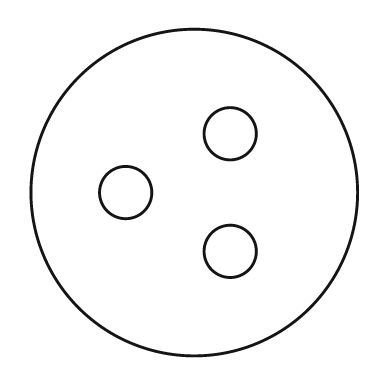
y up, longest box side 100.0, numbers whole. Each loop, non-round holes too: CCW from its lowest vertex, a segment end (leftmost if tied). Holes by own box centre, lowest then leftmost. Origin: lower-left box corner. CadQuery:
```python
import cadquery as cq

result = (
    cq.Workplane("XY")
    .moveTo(50.0, 50.0)
    .circle(50.0)
    .moveTo(61.0, 32.0)
    .circle(8.0)
    .moveTo(29.0, 50.0)
    .circle(8.0)
    .moveTo(61.0, 68.0)
    .circle(8.0)
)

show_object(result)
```